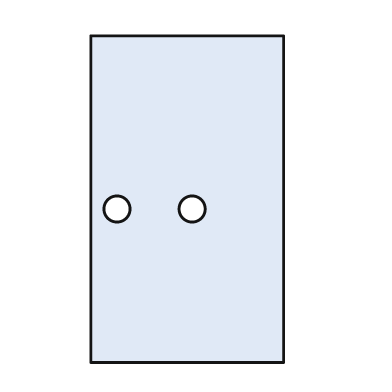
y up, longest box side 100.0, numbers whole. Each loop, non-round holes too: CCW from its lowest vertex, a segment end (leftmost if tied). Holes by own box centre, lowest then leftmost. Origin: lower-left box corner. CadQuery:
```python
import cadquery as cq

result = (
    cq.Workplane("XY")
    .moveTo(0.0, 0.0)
    .lineTo(59.0, 0.0)
    .lineTo(59.0, 100.0)
    .lineTo(0.0, 100.0)
    .close()
    .moveTo(8.0, 47.0)
    .circle(4.0)
    .moveTo(31.0, 47.0)
    .circle(4.0)
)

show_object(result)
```